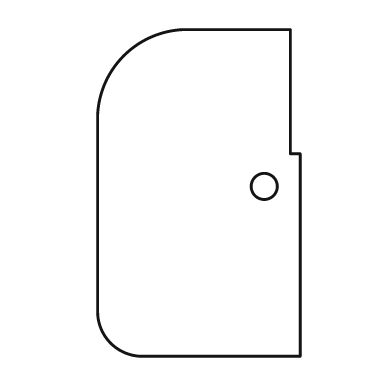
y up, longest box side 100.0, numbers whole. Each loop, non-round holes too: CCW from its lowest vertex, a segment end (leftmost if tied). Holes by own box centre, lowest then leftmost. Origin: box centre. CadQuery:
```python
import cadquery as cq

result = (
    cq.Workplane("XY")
    .moveTo(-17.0, -50.0)
    .lineTo(31.0, -50.0)
    .lineTo(31.0, 12.0)
    .lineTo(28.0, 12.0)
    .lineTo(28.0, 50.0)
    .lineTo(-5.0, 50.0)
    .threePointArc((-23.0, 42.0), (-31.0, 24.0))
    .lineTo(-31.0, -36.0)
    .threePointArc((-27.0, -46.0), (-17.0, -50.0))
    .close()
    .moveTo(20.0, 2.0)
    .circle(4.0)
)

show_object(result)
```